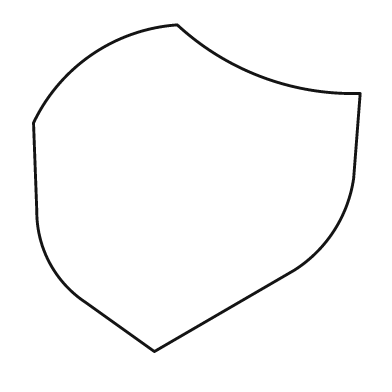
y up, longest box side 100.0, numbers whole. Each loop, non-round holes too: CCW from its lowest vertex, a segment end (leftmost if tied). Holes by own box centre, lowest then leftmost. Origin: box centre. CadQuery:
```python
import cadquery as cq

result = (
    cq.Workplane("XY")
    .moveTo(-13.0, -50.0)
    .lineTo(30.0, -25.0)
    .threePointArc((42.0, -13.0), (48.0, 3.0))
    .lineTo(50.0, 29.0)
    .threePointArc((20.0, 34.0), (-6.0, 50.0))
    .threePointArc((-32.0, 41.0), (-50.0, 20.0))
    .lineTo(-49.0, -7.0)
    .threePointArc((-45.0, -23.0), (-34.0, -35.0))
    .close()
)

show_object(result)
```